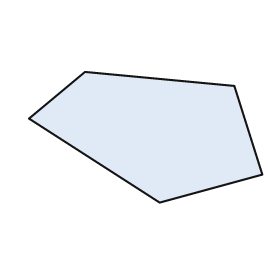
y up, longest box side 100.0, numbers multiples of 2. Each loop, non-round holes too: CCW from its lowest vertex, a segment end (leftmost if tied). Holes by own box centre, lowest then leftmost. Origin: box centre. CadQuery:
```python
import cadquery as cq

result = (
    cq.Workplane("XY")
    .moveTo(6.0, -28.0)
    .lineTo(50.0, -16.0)
    .lineTo(38.0, 22.0)
    .lineTo(-26.0, 28.0)
    .lineTo(-50.0, 8.0)
    .close()
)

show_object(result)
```